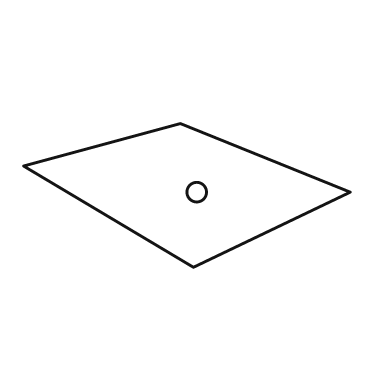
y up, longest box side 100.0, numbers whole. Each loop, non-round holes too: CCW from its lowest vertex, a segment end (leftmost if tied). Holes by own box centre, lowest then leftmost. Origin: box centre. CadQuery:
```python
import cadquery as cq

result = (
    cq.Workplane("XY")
    .moveTo(2.0, -22.0)
    .lineTo(50.0, 1.0)
    .lineTo(-2.0, 22.0)
    .lineTo(-50.0, 9.0)
    .close()
    .moveTo(3.0, 1.0)
    .circle(3.0)
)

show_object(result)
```